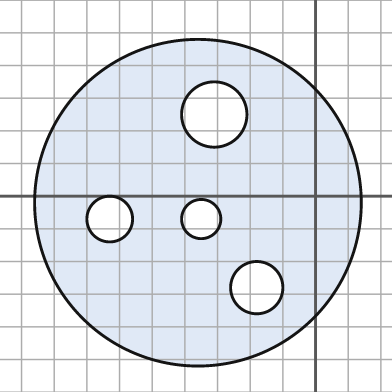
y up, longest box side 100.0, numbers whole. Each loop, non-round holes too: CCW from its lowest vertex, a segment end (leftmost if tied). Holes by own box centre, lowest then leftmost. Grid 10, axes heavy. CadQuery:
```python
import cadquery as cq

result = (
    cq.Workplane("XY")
    .moveTo(-36.0, -2.0)
    .circle(50.0)
    .moveTo(-18.0, -28.0)
    .circle(8.0)
    .moveTo(-63.0, -7.0)
    .circle(7.0)
    .moveTo(-35.0, -7.0)
    .circle(6.0)
    .moveTo(-31.0, 25.0)
    .circle(10.0)
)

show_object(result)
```